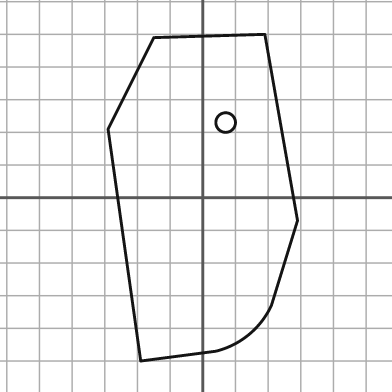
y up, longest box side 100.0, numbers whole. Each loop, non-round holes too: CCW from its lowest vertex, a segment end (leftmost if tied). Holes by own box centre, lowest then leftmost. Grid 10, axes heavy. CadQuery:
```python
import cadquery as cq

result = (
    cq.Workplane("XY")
    .moveTo(-19.0, -50.0)
    .lineTo(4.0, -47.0)
    .threePointArc((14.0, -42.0), (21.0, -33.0))
    .lineTo(29.0, -7.0)
    .lineTo(19.0, 50.0)
    .lineTo(-15.0, 49.0)
    .lineTo(-29.0, 21.0)
    .close()
    .moveTo(7.0, 23.0)
    .circle(3.0)
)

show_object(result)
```